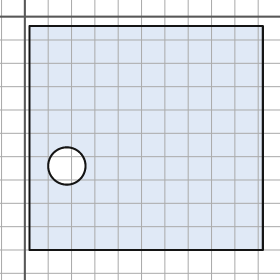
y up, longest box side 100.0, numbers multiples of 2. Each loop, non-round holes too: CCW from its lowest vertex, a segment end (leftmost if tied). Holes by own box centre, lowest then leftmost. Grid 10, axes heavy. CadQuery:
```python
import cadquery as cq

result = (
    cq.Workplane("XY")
    .moveTo(2.0, -100.0)
    .lineTo(102.0, -100.0)
    .lineTo(102.0, -4.0)
    .lineTo(2.0, -4.0)
    .close()
    .moveTo(18.0, -64.0)
    .circle(8.0)
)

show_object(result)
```